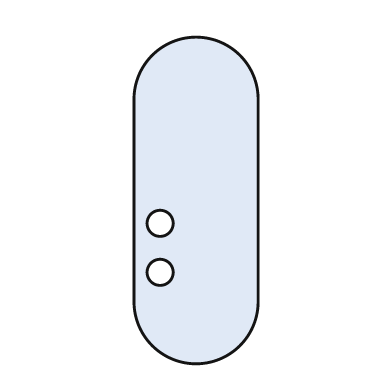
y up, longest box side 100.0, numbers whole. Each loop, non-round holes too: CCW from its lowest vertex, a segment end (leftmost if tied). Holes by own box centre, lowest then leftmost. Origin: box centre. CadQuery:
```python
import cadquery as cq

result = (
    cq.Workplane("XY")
    .moveTo(-19.0, -31.0)
    .threePointArc((0.0, -50.0), (19.0, -31.0))
    .lineTo(19.0, 31.0)
    .threePointArc((0.0, 50.0), (-19.0, 31.0))
    .close()
    .moveTo(-11.0, -22.0)
    .circle(4.0)
    .moveTo(-11.0, -7.0)
    .circle(4.0)
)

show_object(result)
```